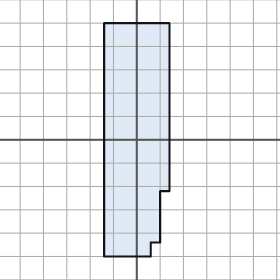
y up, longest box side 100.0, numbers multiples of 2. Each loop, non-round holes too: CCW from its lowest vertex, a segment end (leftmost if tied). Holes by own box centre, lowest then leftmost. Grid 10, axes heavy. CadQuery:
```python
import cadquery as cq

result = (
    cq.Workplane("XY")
    .moveTo(-14.0, -50.0)
    .lineTo(6.0, -50.0)
    .lineTo(6.0, -44.0)
    .lineTo(10.0, -44.0)
    .lineTo(10.0, -22.0)
    .lineTo(14.0, -22.0)
    .lineTo(14.0, 50.0)
    .lineTo(-14.0, 50.0)
    .close()
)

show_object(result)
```